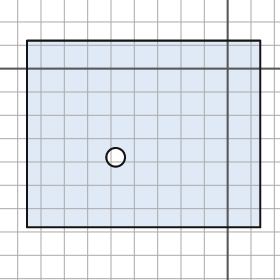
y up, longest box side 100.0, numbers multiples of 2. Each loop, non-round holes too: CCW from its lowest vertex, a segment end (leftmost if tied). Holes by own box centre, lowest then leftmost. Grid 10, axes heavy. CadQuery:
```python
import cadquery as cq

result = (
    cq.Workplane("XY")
    .moveTo(-86.0, -68.0)
    .lineTo(14.0, -68.0)
    .lineTo(14.0, 12.0)
    .lineTo(-86.0, 12.0)
    .close()
    .moveTo(-48.0, -38.0)
    .circle(4.0)
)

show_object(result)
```